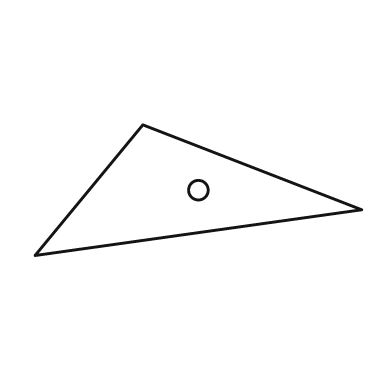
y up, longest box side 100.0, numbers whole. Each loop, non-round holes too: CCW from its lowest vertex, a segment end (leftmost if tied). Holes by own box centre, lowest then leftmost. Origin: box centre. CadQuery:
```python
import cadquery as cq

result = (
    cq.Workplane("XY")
    .moveTo(-50.0, -20.0)
    .lineTo(50.0, -6.0)
    .lineTo(-17.0, 20.0)
    .close()
    .moveTo(0.0, 0.0)
    .circle(3.0)
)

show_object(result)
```